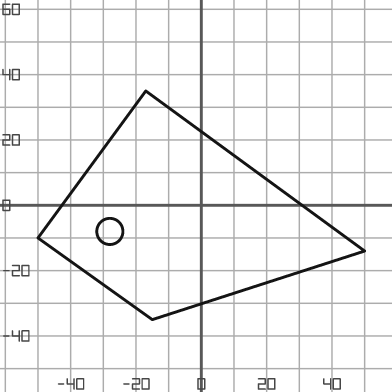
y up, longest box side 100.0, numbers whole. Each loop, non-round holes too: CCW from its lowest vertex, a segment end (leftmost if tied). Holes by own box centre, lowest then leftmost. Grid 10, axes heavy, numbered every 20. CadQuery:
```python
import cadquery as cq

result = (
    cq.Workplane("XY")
    .moveTo(-15.0, -35.0)
    .lineTo(50.0, -14.0)
    .lineTo(-17.0, 35.0)
    .lineTo(-50.0, -10.0)
    .close()
    .moveTo(-28.0, -8.0)
    .circle(4.0)
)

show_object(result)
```